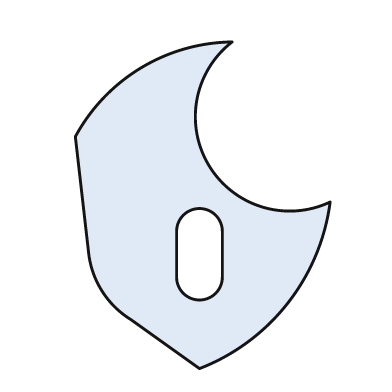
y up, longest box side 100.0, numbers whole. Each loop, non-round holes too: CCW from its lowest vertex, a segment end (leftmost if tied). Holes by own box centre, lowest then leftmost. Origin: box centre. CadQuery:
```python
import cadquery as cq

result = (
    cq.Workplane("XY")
    .moveTo(-1.0, -50.0)
    .threePointArc((26.0, -30.0), (39.0, 1.0))
    .threePointArc((2.0, 12.0), (9.0, 50.0))
    .threePointArc((-19.0, 42.0), (-39.0, 21.0))
    .lineTo(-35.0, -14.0)
    .threePointArc((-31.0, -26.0), (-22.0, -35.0))
    .close()
    .moveTo(-8.0, -22.0)
    .threePointArc((-1.0, -29.0), (6.0, -22.0))
    .lineTo(6.0, -8.0)
    .threePointArc((-1.0, -1.0), (-8.0, -8.0))
    .close()
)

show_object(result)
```